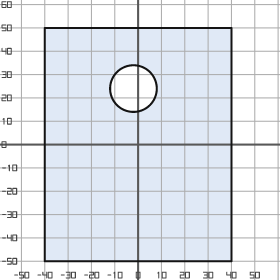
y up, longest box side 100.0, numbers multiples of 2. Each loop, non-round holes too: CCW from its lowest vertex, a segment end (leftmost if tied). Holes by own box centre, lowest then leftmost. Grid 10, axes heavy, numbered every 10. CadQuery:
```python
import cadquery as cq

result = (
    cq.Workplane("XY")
    .moveTo(-40.0, -50.0)
    .lineTo(40.0, -50.0)
    .lineTo(40.0, 50.0)
    .lineTo(-40.0, 50.0)
    .close()
    .moveTo(-2.0, 24.0)
    .circle(10.0)
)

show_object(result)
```